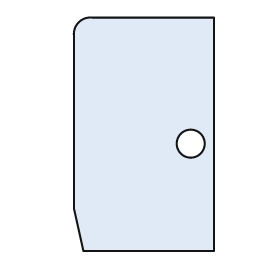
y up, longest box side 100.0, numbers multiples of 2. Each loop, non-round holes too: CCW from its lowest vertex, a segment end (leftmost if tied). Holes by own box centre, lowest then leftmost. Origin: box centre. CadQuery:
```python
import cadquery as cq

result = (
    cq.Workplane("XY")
    .moveTo(-26.0, -50.0)
    .lineTo(30.0, -50.0)
    .lineTo(30.0, 50.0)
    .lineTo(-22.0, 50.0)
    .threePointArc((-28.0, 48.0), (-30.0, 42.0))
    .lineTo(-30.0, -32.0)
    .close()
    .moveTo(20.0, -4.0)
    .circle(6.0)
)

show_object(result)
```